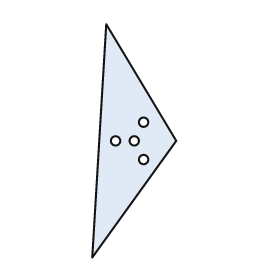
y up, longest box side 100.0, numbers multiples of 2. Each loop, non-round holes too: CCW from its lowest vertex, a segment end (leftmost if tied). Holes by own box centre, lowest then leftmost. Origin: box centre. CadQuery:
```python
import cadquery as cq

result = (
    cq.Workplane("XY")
    .moveTo(-18.0, -50.0)
    .lineTo(18.0, 0.0)
    .lineTo(-12.0, 50.0)
    .close()
    .moveTo(4.0, -8.0)
    .circle(2.0)
    .moveTo(-8.0, 0.0)
    .circle(2.0)
    .moveTo(0.0, 0.0)
    .circle(2.0)
    .moveTo(4.0, 8.0)
    .circle(2.0)
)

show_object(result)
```